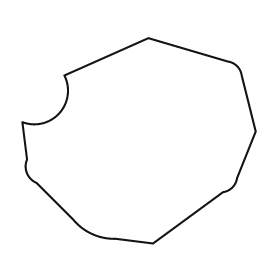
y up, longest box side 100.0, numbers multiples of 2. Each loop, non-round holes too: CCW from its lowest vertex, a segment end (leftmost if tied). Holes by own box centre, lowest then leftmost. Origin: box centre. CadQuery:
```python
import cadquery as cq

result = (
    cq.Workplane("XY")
    .moveTo(6.0, -44.0)
    .lineTo(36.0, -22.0)
    .threePointArc((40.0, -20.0), (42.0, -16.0))
    .lineTo(50.0, 4.0)
    .lineTo(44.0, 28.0)
    .threePointArc((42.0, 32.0), (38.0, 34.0))
    .lineTo(4.0, 44.0)
    .lineTo(-32.0, 28.0)
    .threePointArc((-34.0, 12.0), (-50.0, 8.0))
    .lineTo(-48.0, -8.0)
    .threePointArc((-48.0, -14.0), (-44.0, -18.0))
    .lineTo(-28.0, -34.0)
    .threePointArc((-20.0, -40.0), (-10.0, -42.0))
    .close()
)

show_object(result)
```